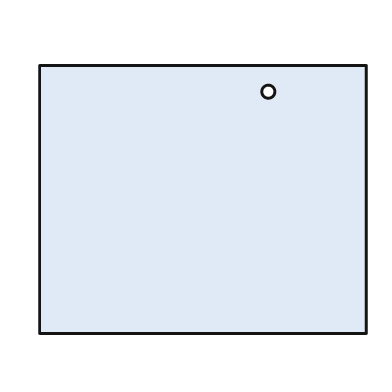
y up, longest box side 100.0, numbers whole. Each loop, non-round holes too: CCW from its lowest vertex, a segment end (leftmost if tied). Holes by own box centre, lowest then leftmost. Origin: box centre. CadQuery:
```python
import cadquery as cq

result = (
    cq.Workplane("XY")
    .moveTo(-50.0, -41.0)
    .lineTo(50.0, -41.0)
    .lineTo(50.0, 41.0)
    .lineTo(-50.0, 41.0)
    .close()
    .moveTo(20.0, 33.0)
    .circle(2.0)
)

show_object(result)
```